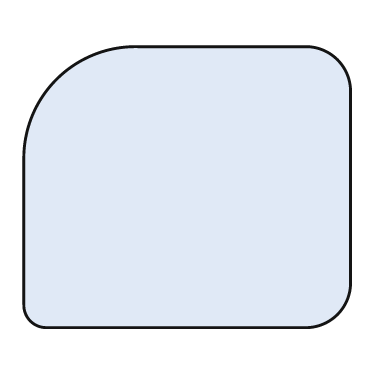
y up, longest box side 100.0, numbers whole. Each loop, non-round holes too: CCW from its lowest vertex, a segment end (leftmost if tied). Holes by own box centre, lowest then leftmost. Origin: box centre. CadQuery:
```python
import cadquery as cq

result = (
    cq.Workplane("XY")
    .moveTo(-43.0, -43.0)
    .lineTo(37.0, -43.0)
    .threePointArc((46.0, -39.0), (50.0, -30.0))
    .lineTo(50.0, 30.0)
    .threePointArc((46.0, 39.0), (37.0, 43.0))
    .lineTo(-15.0, 43.0)
    .threePointArc((-40.0, 33.0), (-50.0, 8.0))
    .lineTo(-50.0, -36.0)
    .threePointArc((-48.0, -41.0), (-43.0, -43.0))
    .close()
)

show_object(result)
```